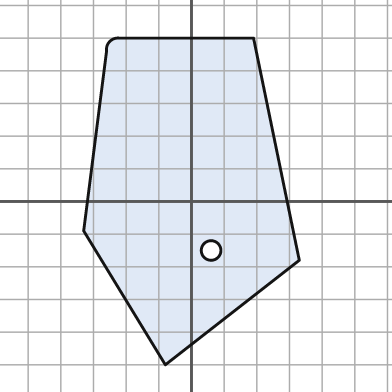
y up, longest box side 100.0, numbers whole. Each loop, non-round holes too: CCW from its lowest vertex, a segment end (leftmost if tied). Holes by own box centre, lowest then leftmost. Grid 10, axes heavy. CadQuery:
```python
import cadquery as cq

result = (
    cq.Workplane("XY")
    .moveTo(-8.0, -50.0)
    .lineTo(33.0, -18.0)
    .lineTo(19.0, 50.0)
    .lineTo(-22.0, 50.0)
    .threePointArc((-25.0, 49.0), (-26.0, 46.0))
    .lineTo(-33.0, -9.0)
    .close()
    .moveTo(6.0, -15.0)
    .circle(3.0)
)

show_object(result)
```